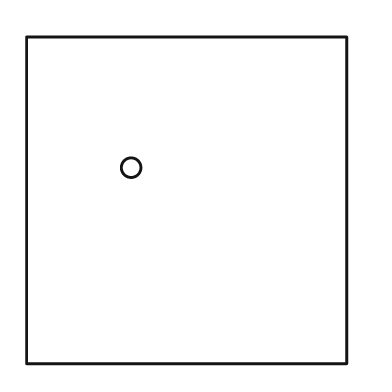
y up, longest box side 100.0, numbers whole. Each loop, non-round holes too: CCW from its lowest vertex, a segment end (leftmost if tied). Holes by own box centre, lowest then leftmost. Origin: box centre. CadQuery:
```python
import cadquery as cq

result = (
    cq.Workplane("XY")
    .moveTo(-49.0, -50.0)
    .lineTo(49.0, -50.0)
    .lineTo(49.0, 50.0)
    .lineTo(-49.0, 50.0)
    .close()
    .moveTo(-17.0, 10.0)
    .circle(3.0)
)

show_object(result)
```